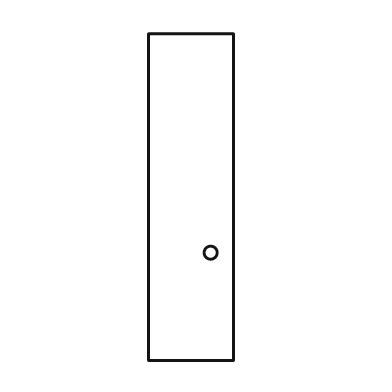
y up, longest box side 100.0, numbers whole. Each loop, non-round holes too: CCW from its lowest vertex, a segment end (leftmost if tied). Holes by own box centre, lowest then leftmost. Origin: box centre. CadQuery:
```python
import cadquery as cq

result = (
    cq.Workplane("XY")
    .moveTo(-13.0, -50.0)
    .lineTo(13.0, -50.0)
    .lineTo(13.0, 50.0)
    .lineTo(-13.0, 50.0)
    .close()
    .moveTo(6.0, -17.0)
    .circle(2.0)
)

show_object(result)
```